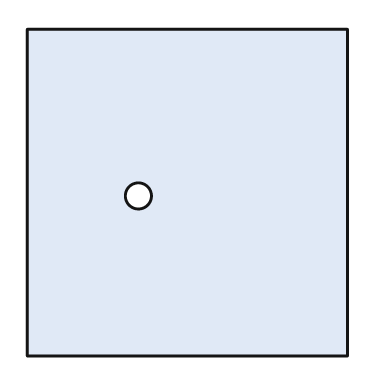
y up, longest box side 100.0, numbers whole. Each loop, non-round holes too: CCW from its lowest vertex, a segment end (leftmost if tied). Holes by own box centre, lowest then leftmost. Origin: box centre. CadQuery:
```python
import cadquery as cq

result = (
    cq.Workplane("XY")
    .moveTo(-49.0, -50.0)
    .lineTo(49.0, -50.0)
    .lineTo(49.0, 50.0)
    .lineTo(-49.0, 50.0)
    .close()
    .moveTo(-15.0, -1.0)
    .circle(4.0)
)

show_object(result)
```